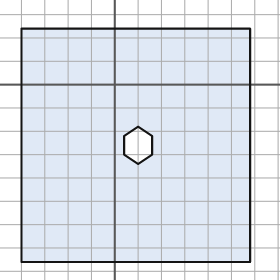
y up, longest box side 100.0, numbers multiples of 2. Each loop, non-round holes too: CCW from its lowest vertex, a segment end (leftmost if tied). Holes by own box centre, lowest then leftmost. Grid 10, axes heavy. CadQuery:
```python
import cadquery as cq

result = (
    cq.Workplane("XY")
    .moveTo(-40.0, -76.0)
    .lineTo(58.0, -76.0)
    .lineTo(58.0, 24.0)
    .lineTo(-40.0, 24.0)
    .close()
    .moveTo(10.0, -34.0)
    .lineTo(16.0, -30.0)
    .lineTo(16.0, -22.0)
    .lineTo(10.0, -18.0)
    .lineTo(4.0, -22.0)
    .lineTo(4.0, -30.0)
    .close()
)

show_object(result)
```